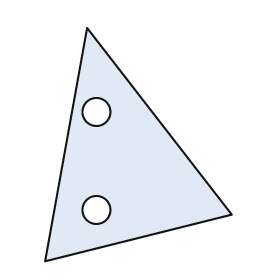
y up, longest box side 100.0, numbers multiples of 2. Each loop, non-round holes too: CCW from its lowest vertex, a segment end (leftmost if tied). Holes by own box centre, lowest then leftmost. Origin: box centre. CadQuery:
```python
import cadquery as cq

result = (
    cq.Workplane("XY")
    .moveTo(-40.0, -50.0)
    .lineTo(40.0, -30.0)
    .lineTo(-22.0, 50.0)
    .close()
    .moveTo(-18.0, -28.0)
    .circle(6.0)
    .moveTo(-18.0, 14.0)
    .circle(6.0)
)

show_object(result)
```